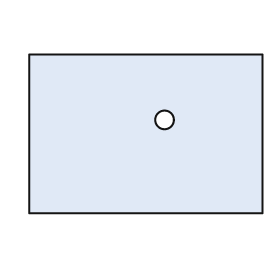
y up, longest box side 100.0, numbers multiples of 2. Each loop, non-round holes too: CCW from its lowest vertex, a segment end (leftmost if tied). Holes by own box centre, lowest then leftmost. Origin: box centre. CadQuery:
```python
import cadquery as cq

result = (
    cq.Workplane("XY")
    .moveTo(-50.0, -34.0)
    .lineTo(50.0, -34.0)
    .lineTo(50.0, 34.0)
    .lineTo(-50.0, 34.0)
    .close()
    .moveTo(8.0, 6.0)
    .circle(4.0)
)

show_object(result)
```